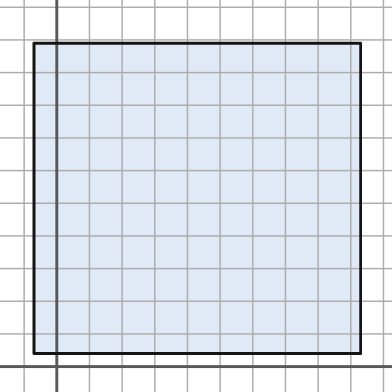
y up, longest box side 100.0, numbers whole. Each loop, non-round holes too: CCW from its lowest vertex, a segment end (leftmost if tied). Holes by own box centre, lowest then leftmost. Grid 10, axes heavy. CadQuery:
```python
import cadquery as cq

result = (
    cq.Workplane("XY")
    .moveTo(-7.0, 4.0)
    .lineTo(93.0, 4.0)
    .lineTo(93.0, 99.0)
    .lineTo(-7.0, 99.0)
    .close()
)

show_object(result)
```